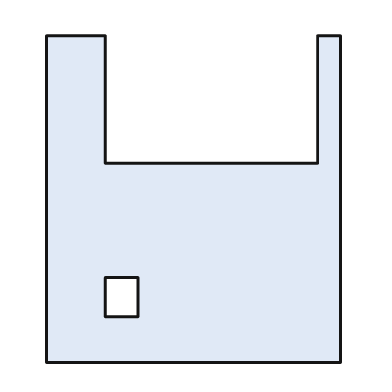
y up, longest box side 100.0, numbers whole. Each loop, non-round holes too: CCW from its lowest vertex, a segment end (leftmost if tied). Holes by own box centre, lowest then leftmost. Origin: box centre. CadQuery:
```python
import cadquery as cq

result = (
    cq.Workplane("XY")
    .moveTo(-45.0, -50.0)
    .lineTo(45.0, -50.0)
    .lineTo(45.0, 50.0)
    .lineTo(38.0, 50.0)
    .lineTo(38.0, 11.0)
    .lineTo(-27.0, 11.0)
    .lineTo(-27.0, 50.0)
    .lineTo(-45.0, 50.0)
    .close()
    .moveTo(-27.0, -36.0)
    .lineTo(-17.0, -36.0)
    .lineTo(-17.0, -24.0)
    .lineTo(-27.0, -24.0)
    .close()
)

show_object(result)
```